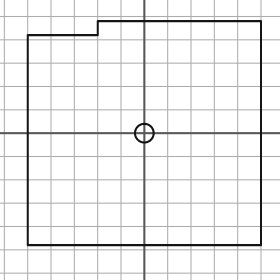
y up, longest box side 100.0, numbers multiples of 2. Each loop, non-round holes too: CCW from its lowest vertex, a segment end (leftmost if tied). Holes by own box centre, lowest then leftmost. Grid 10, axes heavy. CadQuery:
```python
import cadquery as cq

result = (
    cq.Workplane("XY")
    .moveTo(-50.0, -48.0)
    .lineTo(50.0, -48.0)
    .lineTo(50.0, 48.0)
    .lineTo(-20.0, 48.0)
    .lineTo(-20.0, 42.0)
    .lineTo(-50.0, 42.0)
    .close()
    .moveTo(0.0, 0.0)
    .circle(4.0)
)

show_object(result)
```